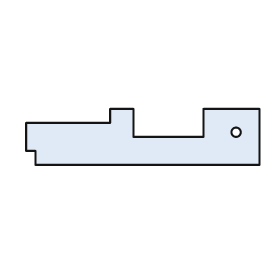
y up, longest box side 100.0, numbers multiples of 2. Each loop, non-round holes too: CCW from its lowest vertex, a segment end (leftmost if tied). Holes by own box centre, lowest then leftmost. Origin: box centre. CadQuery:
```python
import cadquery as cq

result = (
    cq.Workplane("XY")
    .moveTo(-46.0, -12.0)
    .lineTo(50.0, -12.0)
    .lineTo(50.0, 12.0)
    .lineTo(26.0, 12.0)
    .lineTo(26.0, 0.0)
    .lineTo(-4.0, 0.0)
    .lineTo(-4.0, 12.0)
    .lineTo(-14.0, 12.0)
    .lineTo(-14.0, 6.0)
    .lineTo(-50.0, 6.0)
    .lineTo(-50.0, -6.0)
    .lineTo(-46.0, -6.0)
    .close()
    .moveTo(40.0, 2.0)
    .circle(2.0)
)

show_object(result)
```